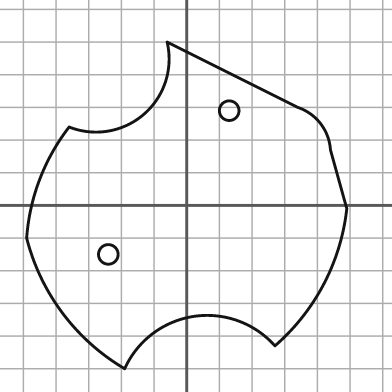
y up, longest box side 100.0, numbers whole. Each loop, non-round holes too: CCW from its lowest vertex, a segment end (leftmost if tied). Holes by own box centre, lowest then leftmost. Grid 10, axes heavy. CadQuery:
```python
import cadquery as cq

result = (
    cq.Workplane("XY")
    .moveTo(-19.0, -50.0)
    .threePointArc((2.0, -34.0), (27.0, -43.0))
    .threePointArc((42.0, -24.0), (49.0, -1.0))
    .lineTo(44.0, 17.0)
    .threePointArc((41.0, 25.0), (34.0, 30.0))
    .lineTo(-6.0, 50.0)
    .threePointArc((-13.0, 28.0), (-36.0, 24.0))
    .threePointArc((-45.0, 8.0), (-49.0, -10.0))
    .threePointArc((-38.0, -33.0), (-19.0, -50.0))
    .close()
    .moveTo(-24.0, -15.0)
    .circle(3.0)
    .moveTo(13.0, 29.0)
    .circle(3.0)
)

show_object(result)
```